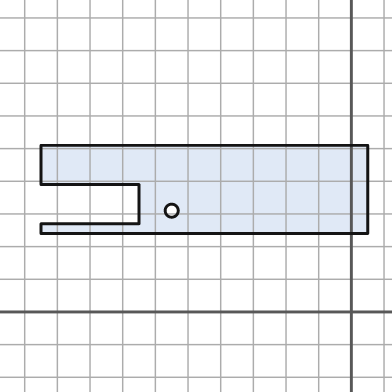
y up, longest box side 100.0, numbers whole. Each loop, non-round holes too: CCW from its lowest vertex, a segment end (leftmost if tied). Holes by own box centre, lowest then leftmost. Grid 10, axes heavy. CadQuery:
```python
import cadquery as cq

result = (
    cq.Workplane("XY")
    .moveTo(-95.0, 24.0)
    .lineTo(5.0, 24.0)
    .lineTo(5.0, 51.0)
    .lineTo(-95.0, 51.0)
    .lineTo(-95.0, 39.0)
    .lineTo(-65.0, 39.0)
    .lineTo(-65.0, 27.0)
    .lineTo(-95.0, 27.0)
    .close()
    .moveTo(-55.0, 31.0)
    .circle(2.0)
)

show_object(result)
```